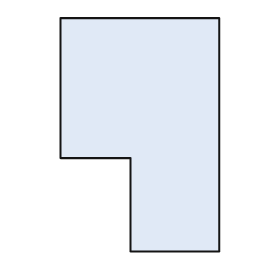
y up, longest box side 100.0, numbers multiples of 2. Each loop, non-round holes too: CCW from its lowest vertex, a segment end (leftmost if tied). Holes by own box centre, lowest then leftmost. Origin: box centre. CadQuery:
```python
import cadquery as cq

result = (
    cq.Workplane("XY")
    .moveTo(-4.0, -50.0)
    .lineTo(34.0, -50.0)
    .lineTo(34.0, 50.0)
    .lineTo(-34.0, 50.0)
    .lineTo(-34.0, -10.0)
    .lineTo(-4.0, -10.0)
    .close()
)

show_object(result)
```